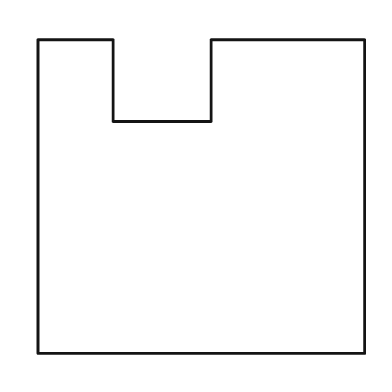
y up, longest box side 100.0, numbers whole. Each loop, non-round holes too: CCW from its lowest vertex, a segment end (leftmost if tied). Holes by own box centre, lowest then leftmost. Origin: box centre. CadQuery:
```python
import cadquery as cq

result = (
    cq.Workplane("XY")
    .moveTo(-50.0, -48.0)
    .lineTo(50.0, -48.0)
    .lineTo(50.0, 48.0)
    .lineTo(3.0, 48.0)
    .lineTo(3.0, 23.0)
    .lineTo(-27.0, 23.0)
    .lineTo(-27.0, 48.0)
    .lineTo(-50.0, 48.0)
    .close()
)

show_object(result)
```